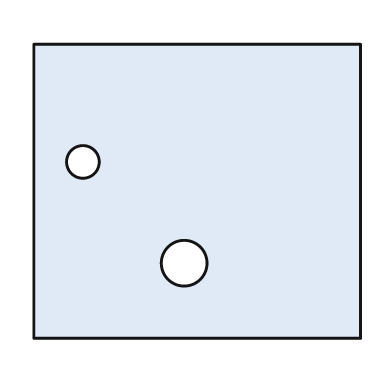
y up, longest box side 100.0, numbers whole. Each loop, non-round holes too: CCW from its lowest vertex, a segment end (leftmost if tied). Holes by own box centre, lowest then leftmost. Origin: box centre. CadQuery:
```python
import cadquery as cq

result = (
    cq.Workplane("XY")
    .moveTo(-50.0, -45.0)
    .lineTo(50.0, -45.0)
    .lineTo(50.0, 45.0)
    .lineTo(-50.0, 45.0)
    .close()
    .moveTo(-4.0, -22.0)
    .circle(7.0)
    .moveTo(-35.0, 9.0)
    .circle(5.0)
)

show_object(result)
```